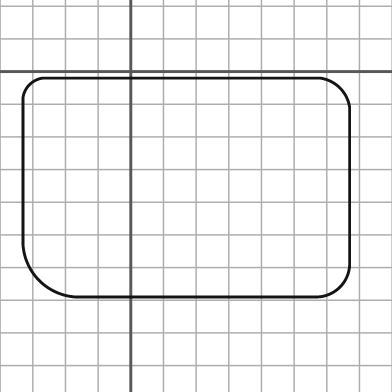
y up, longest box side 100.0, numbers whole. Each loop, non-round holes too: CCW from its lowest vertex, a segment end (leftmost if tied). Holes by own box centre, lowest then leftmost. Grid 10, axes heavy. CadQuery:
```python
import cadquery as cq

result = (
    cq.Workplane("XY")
    .moveTo(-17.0, -69.0)
    .lineTo(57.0, -69.0)
    .threePointArc((64.0, -66.0), (67.0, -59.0))
    .lineTo(67.0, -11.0)
    .threePointArc((64.0, -5.0), (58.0, -2.0))
    .lineTo(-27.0, -2.0)
    .threePointArc((-31.0, -4.0), (-33.0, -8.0))
    .lineTo(-33.0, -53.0)
    .threePointArc((-28.0, -64.0), (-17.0, -69.0))
    .close()
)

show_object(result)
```